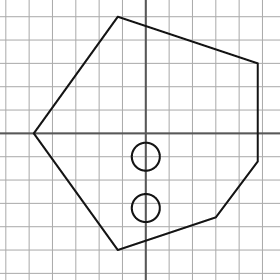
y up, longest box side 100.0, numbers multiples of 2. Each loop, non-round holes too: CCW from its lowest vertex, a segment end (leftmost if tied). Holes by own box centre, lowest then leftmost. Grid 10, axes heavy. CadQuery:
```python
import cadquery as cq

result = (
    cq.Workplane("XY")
    .moveTo(-12.0, -50.0)
    .lineTo(30.0, -36.0)
    .lineTo(48.0, -12.0)
    .lineTo(48.0, 30.0)
    .lineTo(-12.0, 50.0)
    .lineTo(-48.0, 0.0)
    .close()
    .moveTo(0.0, -32.0)
    .circle(6.0)
    .moveTo(0.0, -10.0)
    .circle(6.0)
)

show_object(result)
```